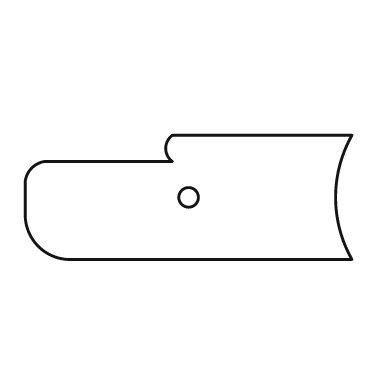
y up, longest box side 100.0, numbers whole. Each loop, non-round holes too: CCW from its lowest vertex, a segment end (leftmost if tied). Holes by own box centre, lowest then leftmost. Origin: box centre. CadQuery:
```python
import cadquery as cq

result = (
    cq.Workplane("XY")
    .moveTo(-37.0, -19.0)
    .lineTo(50.0, -19.0)
    .threePointArc((45.0, 0.0), (50.0, 19.0))
    .lineTo(-5.0, 19.0)
    .threePointArc((-7.0, 15.0), (-5.0, 11.0))
    .lineTo(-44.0, 11.0)
    .threePointArc((-48.0, 9.0), (-50.0, 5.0))
    .lineTo(-50.0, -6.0)
    .threePointArc((-46.0, -15.0), (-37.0, -19.0))
    .close()
    .moveTo(0.0, 0.0)
    .circle(3.0)
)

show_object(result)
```